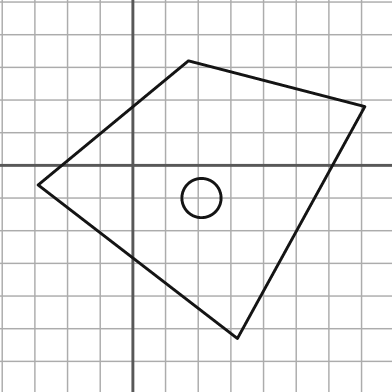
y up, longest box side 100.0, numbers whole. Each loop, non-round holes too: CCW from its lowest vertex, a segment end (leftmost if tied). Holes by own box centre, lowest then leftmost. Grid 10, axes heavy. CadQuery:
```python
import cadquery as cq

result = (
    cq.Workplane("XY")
    .moveTo(32.0, -53.0)
    .lineTo(71.0, 18.0)
    .lineTo(17.0, 32.0)
    .lineTo(-29.0, -6.0)
    .close()
    .moveTo(21.0, -10.0)
    .circle(6.0)
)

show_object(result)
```